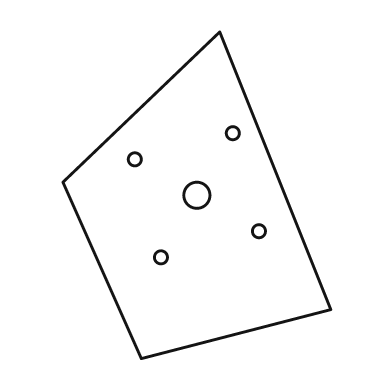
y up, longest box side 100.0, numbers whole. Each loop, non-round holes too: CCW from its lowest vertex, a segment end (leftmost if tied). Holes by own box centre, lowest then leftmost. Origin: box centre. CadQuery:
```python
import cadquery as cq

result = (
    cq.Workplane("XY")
    .moveTo(-17.0, -50.0)
    .lineTo(41.0, -35.0)
    .lineTo(7.0, 50.0)
    .lineTo(-41.0, 4.0)
    .close()
    .moveTo(-11.0, -19.0)
    .circle(2.0)
    .moveTo(19.0, -11.0)
    .circle(2.0)
    .moveTo(0.0, 0.0)
    .circle(4.0)
    .moveTo(-19.0, 11.0)
    .circle(2.0)
    .moveTo(11.0, 19.0)
    .circle(2.0)
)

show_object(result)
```